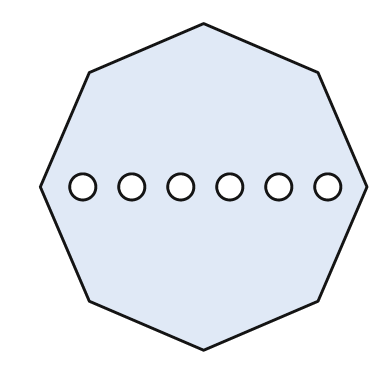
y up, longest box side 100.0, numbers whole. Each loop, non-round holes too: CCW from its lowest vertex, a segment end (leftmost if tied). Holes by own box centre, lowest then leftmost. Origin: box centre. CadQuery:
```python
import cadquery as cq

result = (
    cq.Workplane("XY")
    .moveTo(0.0, -50.0)
    .lineTo(35.0, -35.0)
    .lineTo(50.0, 0.0)
    .lineTo(35.0, 35.0)
    .lineTo(0.0, 50.0)
    .lineTo(-35.0, 35.0)
    .lineTo(-50.0, 0.0)
    .lineTo(-35.0, -35.0)
    .close()
    .moveTo(-37.0, 0.0)
    .circle(4.0)
    .moveTo(-22.0, 0.0)
    .circle(4.0)
    .moveTo(-7.0, 0.0)
    .circle(4.0)
    .moveTo(8.0, 0.0)
    .circle(4.0)
    .moveTo(23.0, 0.0)
    .circle(4.0)
    .moveTo(38.0, 0.0)
    .circle(4.0)
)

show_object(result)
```